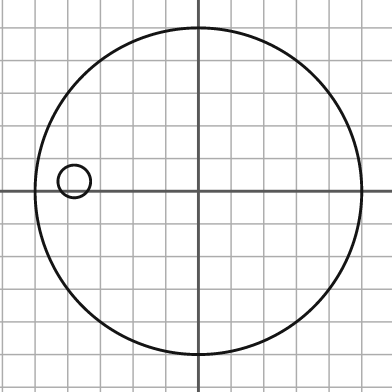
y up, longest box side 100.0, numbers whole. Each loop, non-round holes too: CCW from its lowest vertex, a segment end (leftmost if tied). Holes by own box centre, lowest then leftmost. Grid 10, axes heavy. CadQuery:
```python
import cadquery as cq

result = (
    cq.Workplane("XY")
    .moveTo(0.0, 0.0)
    .circle(50.0)
    .moveTo(-38.0, 3.0)
    .circle(5.0)
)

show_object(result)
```